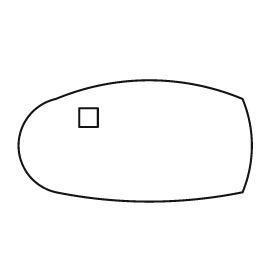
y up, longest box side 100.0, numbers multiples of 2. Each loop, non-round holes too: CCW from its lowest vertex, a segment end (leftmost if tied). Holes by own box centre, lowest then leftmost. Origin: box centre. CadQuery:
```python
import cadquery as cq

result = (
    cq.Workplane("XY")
    .moveTo(-34.0, -22.0)
    .threePointArc((6.0, -26.0), (46.0, -22.0))
    .threePointArc((50.0, -2.0), (46.0, 18.0))
    .threePointArc((6.0, 26.0), (-34.0, 18.0))
    .threePointArc((-50.0, -2.0), (-34.0, -22.0))
    .close()
    .moveTo(-24.0, 6.0)
    .lineTo(-16.0, 6.0)
    .lineTo(-16.0, 14.0)
    .lineTo(-24.0, 14.0)
    .close()
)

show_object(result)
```